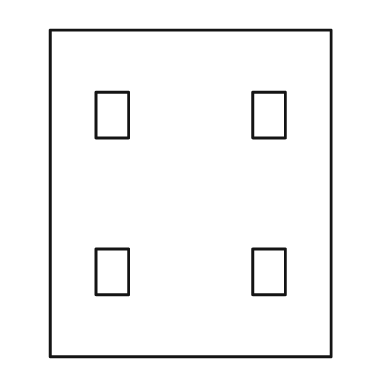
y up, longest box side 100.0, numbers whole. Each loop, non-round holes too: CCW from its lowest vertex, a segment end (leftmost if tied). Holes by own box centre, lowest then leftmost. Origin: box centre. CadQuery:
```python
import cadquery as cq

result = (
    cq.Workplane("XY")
    .moveTo(-43.0, -50.0)
    .lineTo(43.0, -50.0)
    .lineTo(43.0, 50.0)
    .lineTo(-43.0, 50.0)
    .close()
    .moveTo(-29.0, -31.0)
    .lineTo(-19.0, -31.0)
    .lineTo(-19.0, -17.0)
    .lineTo(-29.0, -17.0)
    .close()
    .moveTo(19.0, -31.0)
    .lineTo(29.0, -31.0)
    .lineTo(29.0, -17.0)
    .lineTo(19.0, -17.0)
    .close()
    .moveTo(-29.0, 17.0)
    .lineTo(-19.0, 17.0)
    .lineTo(-19.0, 31.0)
    .lineTo(-29.0, 31.0)
    .close()
    .moveTo(19.0, 17.0)
    .lineTo(29.0, 17.0)
    .lineTo(29.0, 31.0)
    .lineTo(19.0, 31.0)
    .close()
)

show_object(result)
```